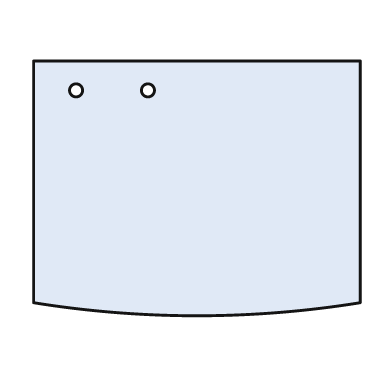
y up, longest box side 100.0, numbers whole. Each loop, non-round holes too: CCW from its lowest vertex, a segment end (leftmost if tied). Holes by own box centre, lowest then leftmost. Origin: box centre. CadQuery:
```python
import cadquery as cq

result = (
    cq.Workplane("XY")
    .moveTo(-50.0, -35.0)
    .threePointArc((0.0, -39.0), (50.0, -35.0))
    .lineTo(50.0, 39.0)
    .lineTo(-50.0, 39.0)
    .close()
    .moveTo(-37.0, 30.0)
    .circle(2.0)
    .moveTo(-15.0, 30.0)
    .circle(2.0)
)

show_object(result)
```